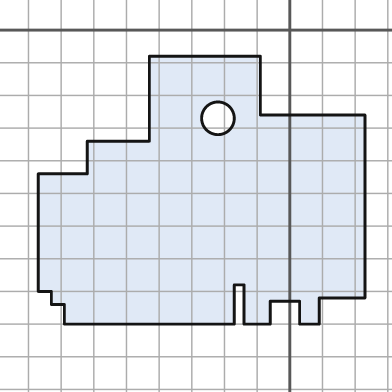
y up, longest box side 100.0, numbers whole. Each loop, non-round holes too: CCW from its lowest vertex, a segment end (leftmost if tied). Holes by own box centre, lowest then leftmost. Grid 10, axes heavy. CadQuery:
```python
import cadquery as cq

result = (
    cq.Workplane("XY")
    .moveTo(-69.0, -90.0)
    .lineTo(-17.0, -90.0)
    .lineTo(-17.0, -78.0)
    .lineTo(-14.0, -78.0)
    .lineTo(-14.0, -90.0)
    .lineTo(-6.0, -90.0)
    .lineTo(-6.0, -83.0)
    .lineTo(3.0, -83.0)
    .lineTo(3.0, -90.0)
    .lineTo(9.0, -90.0)
    .lineTo(9.0, -82.0)
    .lineTo(23.0, -82.0)
    .lineTo(23.0, -26.0)
    .lineTo(-9.0, -26.0)
    .lineTo(-9.0, -8.0)
    .lineTo(-43.0, -8.0)
    .lineTo(-43.0, -34.0)
    .lineTo(-62.0, -34.0)
    .lineTo(-62.0, -44.0)
    .lineTo(-77.0, -44.0)
    .lineTo(-77.0, -80.0)
    .lineTo(-73.0, -80.0)
    .lineTo(-73.0, -84.0)
    .lineTo(-69.0, -84.0)
    .close()
    .moveTo(-22.0, -27.0)
    .circle(5.0)
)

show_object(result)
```